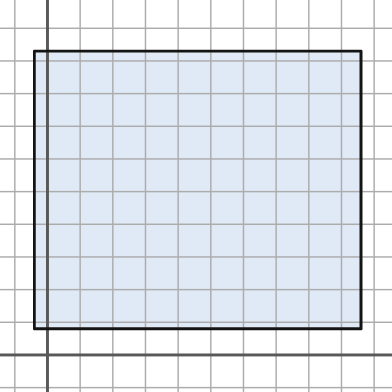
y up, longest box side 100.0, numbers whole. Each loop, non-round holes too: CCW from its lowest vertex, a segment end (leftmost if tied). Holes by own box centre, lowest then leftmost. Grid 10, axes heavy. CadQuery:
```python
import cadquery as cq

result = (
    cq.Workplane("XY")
    .moveTo(-4.0, 8.0)
    .lineTo(96.0, 8.0)
    .lineTo(96.0, 93.0)
    .lineTo(-4.0, 93.0)
    .close()
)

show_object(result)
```